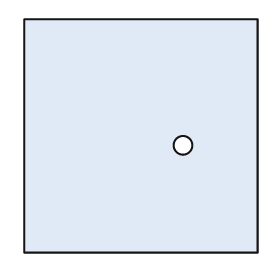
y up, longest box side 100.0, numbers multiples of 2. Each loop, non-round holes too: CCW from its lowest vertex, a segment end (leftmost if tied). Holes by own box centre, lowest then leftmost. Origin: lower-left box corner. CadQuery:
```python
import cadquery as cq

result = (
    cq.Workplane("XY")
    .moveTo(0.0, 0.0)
    .lineTo(100.0, 0.0)
    .lineTo(100.0, 100.0)
    .lineTo(0.0, 100.0)
    .close()
    .moveTo(68.0, 46.0)
    .circle(4.0)
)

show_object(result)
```